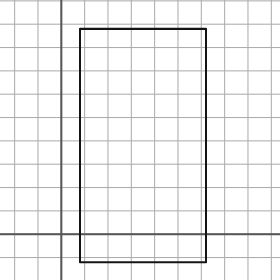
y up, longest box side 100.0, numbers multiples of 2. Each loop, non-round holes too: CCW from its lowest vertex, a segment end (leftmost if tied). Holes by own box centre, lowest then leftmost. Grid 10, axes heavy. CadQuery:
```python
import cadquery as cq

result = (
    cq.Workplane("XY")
    .moveTo(8.0, -12.0)
    .lineTo(62.0, -12.0)
    .lineTo(62.0, 88.0)
    .lineTo(8.0, 88.0)
    .close()
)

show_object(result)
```